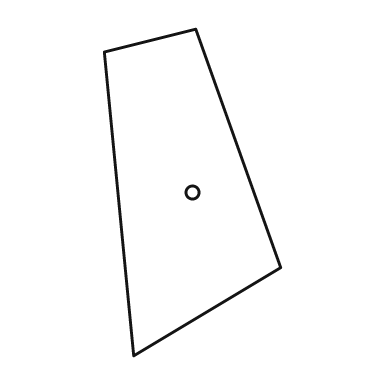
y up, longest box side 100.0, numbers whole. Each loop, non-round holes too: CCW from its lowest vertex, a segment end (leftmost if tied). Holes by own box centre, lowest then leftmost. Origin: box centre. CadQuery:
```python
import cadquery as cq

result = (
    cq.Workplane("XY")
    .moveTo(-18.0, -50.0)
    .lineTo(27.0, -23.0)
    .lineTo(1.0, 50.0)
    .lineTo(-27.0, 43.0)
    .close()
    .moveTo(0.0, 0.0)
    .circle(2.0)
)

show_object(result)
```